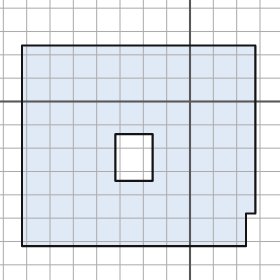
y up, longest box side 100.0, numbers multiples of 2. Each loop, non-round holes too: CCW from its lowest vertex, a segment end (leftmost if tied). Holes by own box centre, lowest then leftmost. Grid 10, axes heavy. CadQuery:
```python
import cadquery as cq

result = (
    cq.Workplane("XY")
    .moveTo(-72.0, -62.0)
    .lineTo(24.0, -62.0)
    .lineTo(24.0, -48.0)
    .lineTo(28.0, -48.0)
    .lineTo(28.0, 24.0)
    .lineTo(-72.0, 24.0)
    .close()
    .moveTo(-32.0, -34.0)
    .lineTo(-16.0, -34.0)
    .lineTo(-16.0, -14.0)
    .lineTo(-32.0, -14.0)
    .close()
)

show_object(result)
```